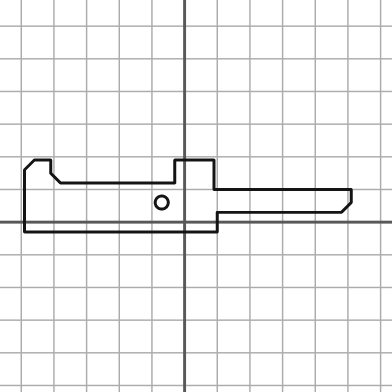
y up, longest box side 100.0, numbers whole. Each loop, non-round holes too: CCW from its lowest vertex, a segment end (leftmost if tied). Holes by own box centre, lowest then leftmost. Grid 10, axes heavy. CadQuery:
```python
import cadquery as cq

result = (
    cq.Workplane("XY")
    .moveTo(-49.0, -3.0)
    .lineTo(10.0, -3.0)
    .lineTo(10.0, 3.0)
    .lineTo(48.0, 3.0)
    .lineTo(51.0, 6.0)
    .lineTo(51.0, 10.0)
    .lineTo(9.0, 10.0)
    .lineTo(9.0, 19.0)
    .lineTo(-3.0, 19.0)
    .lineTo(-3.0, 12.0)
    .lineTo(-38.0, 12.0)
    .lineTo(-41.0, 15.0)
    .lineTo(-41.0, 19.0)
    .lineTo(-46.0, 19.0)
    .lineTo(-49.0, 16.0)
    .close()
    .moveTo(-7.0, 6.0)
    .circle(2.0)
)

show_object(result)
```